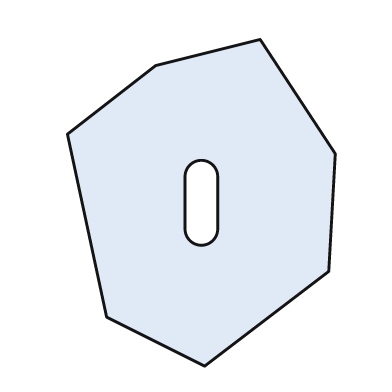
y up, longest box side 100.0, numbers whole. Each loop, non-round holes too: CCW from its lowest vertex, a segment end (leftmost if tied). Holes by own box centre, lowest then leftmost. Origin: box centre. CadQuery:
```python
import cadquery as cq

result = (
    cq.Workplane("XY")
    .moveTo(1.0, -50.0)
    .lineTo(39.0, -21.0)
    .lineTo(41.0, 15.0)
    .lineTo(18.0, 50.0)
    .lineTo(-14.0, 42.0)
    .lineTo(-41.0, 21.0)
    .lineTo(-29.0, -35.0)
    .close()
    .moveTo(-5.0, -8.0)
    .threePointArc((0.0, -13.0), (5.0, -8.0))
    .lineTo(5.0, 8.0)
    .threePointArc((0.0, 13.0), (-5.0, 8.0))
    .close()
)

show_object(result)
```